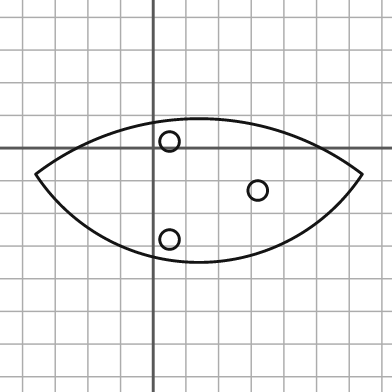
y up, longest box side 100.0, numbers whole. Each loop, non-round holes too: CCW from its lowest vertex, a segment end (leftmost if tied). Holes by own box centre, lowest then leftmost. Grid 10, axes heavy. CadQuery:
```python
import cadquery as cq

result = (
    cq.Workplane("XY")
    .moveTo(-36.0, -8.0)
    .threePointArc((14.0, -35.0), (64.0, -8.0))
    .threePointArc((14.0, 9.0), (-36.0, -8.0))
    .close()
    .moveTo(5.0, -28.0)
    .circle(3.0)
    .moveTo(32.0, -13.0)
    .circle(3.0)
    .moveTo(5.0, 2.0)
    .circle(3.0)
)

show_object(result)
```